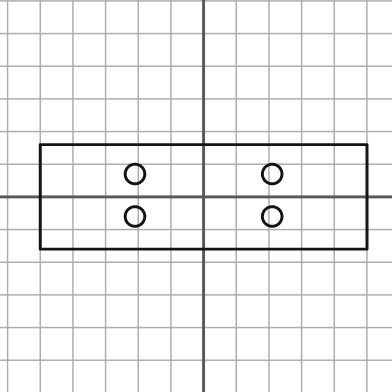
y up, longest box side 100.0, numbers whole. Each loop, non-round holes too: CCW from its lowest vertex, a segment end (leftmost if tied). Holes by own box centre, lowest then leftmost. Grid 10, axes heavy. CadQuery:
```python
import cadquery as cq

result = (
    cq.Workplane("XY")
    .moveTo(-50.0, -16.0)
    .lineTo(50.0, -16.0)
    .lineTo(50.0, 16.0)
    .lineTo(-50.0, 16.0)
    .close()
    .moveTo(-21.0, -6.0)
    .circle(3.0)
    .moveTo(21.0, -6.0)
    .circle(3.0)
    .moveTo(-21.0, 7.0)
    .circle(3.0)
    .moveTo(21.0, 7.0)
    .circle(3.0)
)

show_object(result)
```